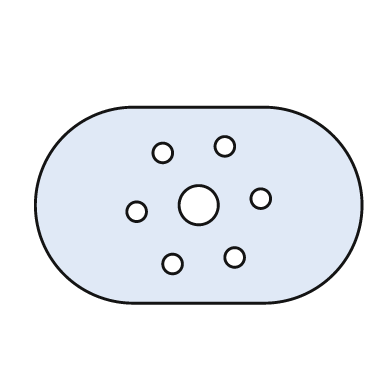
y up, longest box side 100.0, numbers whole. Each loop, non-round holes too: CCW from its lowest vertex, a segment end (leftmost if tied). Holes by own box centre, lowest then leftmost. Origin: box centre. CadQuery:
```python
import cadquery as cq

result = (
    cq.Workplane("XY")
    .moveTo(-20.0, -30.0)
    .lineTo(20.0, -30.0)
    .threePointArc((50.0, 0.0), (20.0, 30.0))
    .lineTo(-20.0, 30.0)
    .threePointArc((-50.0, 0.0), (-20.0, -30.0))
    .close()
    .moveTo(-8.0, -18.0)
    .circle(3.0)
    .moveTo(11.0, -16.0)
    .circle(3.0)
    .moveTo(-19.0, -2.0)
    .circle(3.0)
    .moveTo(0.0, 0.0)
    .circle(6.0)
    .moveTo(19.0, 2.0)
    .circle(3.0)
    .moveTo(-11.0, 16.0)
    .circle(3.0)
    .moveTo(8.0, 18.0)
    .circle(3.0)
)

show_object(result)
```